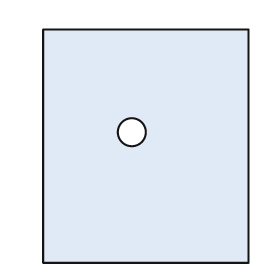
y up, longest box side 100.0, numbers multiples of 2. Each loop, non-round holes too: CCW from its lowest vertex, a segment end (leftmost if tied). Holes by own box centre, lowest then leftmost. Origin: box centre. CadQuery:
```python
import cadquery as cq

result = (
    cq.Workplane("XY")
    .moveTo(-44.0, -50.0)
    .lineTo(44.0, -50.0)
    .lineTo(44.0, 50.0)
    .lineTo(-44.0, 50.0)
    .close()
    .moveTo(-6.0, 6.0)
    .circle(6.0)
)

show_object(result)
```